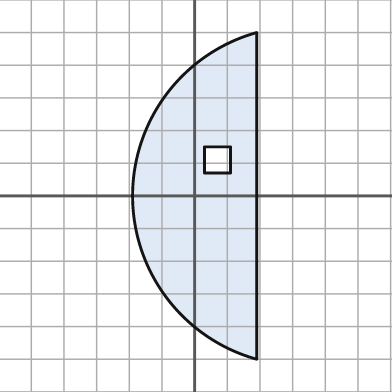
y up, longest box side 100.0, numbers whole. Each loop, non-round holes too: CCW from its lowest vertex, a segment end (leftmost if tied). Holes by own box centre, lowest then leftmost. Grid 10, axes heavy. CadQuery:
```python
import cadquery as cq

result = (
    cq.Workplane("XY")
    .moveTo(19.0, -50.0)
    .lineTo(19.0, 50.0)
    .threePointArc((-19.0, 0.0), (19.0, -50.0))
    .close()
    .moveTo(3.0, 7.0)
    .lineTo(11.0, 7.0)
    .lineTo(11.0, 15.0)
    .lineTo(3.0, 15.0)
    .close()
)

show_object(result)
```